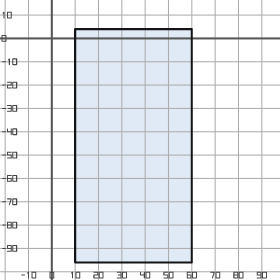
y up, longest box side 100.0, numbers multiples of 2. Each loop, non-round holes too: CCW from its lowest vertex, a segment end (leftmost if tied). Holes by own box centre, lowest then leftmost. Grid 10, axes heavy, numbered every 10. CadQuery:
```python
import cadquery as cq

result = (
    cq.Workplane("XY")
    .moveTo(10.0, -96.0)
    .lineTo(60.0, -96.0)
    .lineTo(60.0, 4.0)
    .lineTo(10.0, 4.0)
    .close()
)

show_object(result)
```